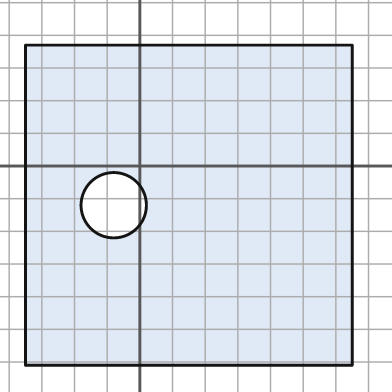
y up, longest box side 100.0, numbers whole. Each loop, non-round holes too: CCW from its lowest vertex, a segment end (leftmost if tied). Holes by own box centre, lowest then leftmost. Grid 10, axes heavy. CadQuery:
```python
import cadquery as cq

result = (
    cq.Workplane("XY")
    .moveTo(-35.0, -61.0)
    .lineTo(65.0, -61.0)
    .lineTo(65.0, 37.0)
    .lineTo(-35.0, 37.0)
    .close()
    .moveTo(-8.0, -12.0)
    .circle(10.0)
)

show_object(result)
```